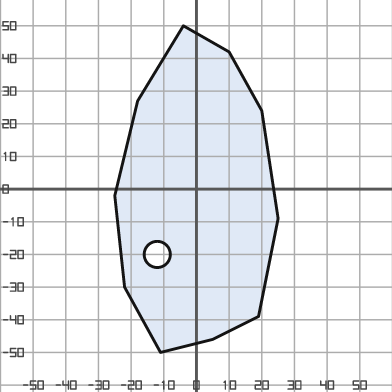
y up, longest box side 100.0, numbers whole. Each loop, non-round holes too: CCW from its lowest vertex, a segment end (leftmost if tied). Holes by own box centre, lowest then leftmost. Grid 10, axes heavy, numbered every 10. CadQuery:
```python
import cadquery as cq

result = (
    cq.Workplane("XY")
    .moveTo(-11.0, -50.0)
    .lineTo(5.0, -46.0)
    .lineTo(19.0, -39.0)
    .lineTo(25.0, -9.0)
    .lineTo(20.0, 24.0)
    .lineTo(10.0, 42.0)
    .lineTo(-4.0, 50.0)
    .lineTo(-18.0, 27.0)
    .lineTo(-25.0, -2.0)
    .lineTo(-22.0, -30.0)
    .close()
    .moveTo(-12.0, -20.0)
    .circle(4.0)
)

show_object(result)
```